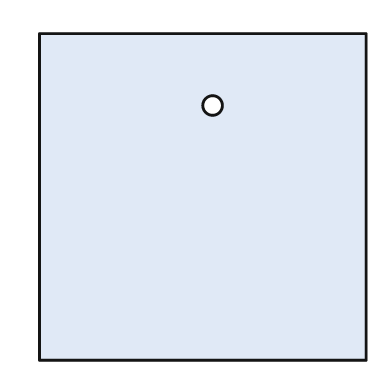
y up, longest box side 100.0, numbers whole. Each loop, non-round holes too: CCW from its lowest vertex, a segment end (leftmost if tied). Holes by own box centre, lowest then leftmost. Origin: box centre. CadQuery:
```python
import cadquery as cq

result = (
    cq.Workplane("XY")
    .moveTo(-50.0, -50.0)
    .lineTo(50.0, -50.0)
    .lineTo(50.0, 50.0)
    .lineTo(-50.0, 50.0)
    .close()
    .moveTo(3.0, 28.0)
    .circle(3.0)
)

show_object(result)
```